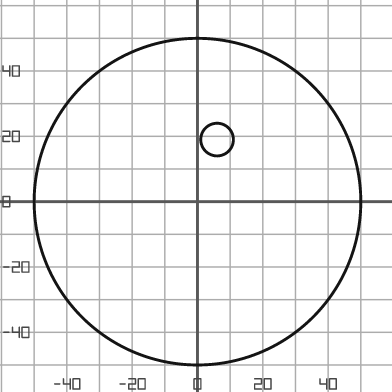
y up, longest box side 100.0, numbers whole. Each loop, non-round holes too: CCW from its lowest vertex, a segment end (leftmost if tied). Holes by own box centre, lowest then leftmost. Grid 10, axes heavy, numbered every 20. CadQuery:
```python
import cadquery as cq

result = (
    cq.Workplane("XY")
    .moveTo(0.0, 0.0)
    .circle(50.0)
    .moveTo(6.0, 19.0)
    .circle(5.0)
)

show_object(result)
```